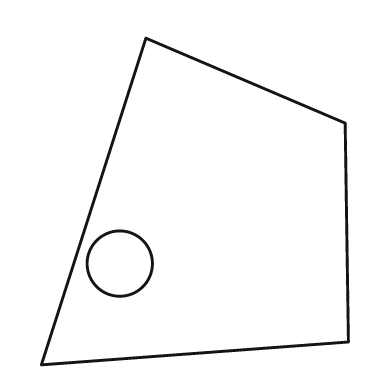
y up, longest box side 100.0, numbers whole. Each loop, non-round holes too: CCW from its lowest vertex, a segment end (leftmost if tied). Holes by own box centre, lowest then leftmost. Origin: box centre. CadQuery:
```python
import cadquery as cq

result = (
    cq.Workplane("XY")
    .moveTo(-47.0, -50.0)
    .lineTo(47.0, -43.0)
    .lineTo(46.0, 24.0)
    .lineTo(-15.0, 50.0)
    .close()
    .moveTo(-23.0, -19.0)
    .circle(10.0)
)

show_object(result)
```